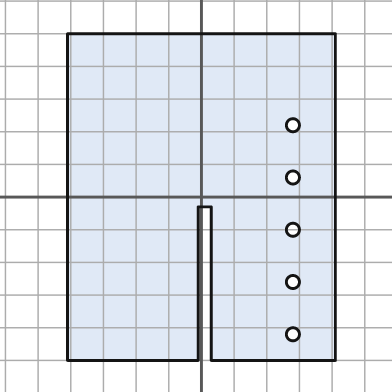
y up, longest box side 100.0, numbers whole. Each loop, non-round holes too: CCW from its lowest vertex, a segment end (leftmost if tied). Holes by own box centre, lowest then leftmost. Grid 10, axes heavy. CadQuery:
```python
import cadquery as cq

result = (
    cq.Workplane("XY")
    .moveTo(-41.0, -50.0)
    .lineTo(-1.0, -50.0)
    .lineTo(-1.0, -3.0)
    .lineTo(3.0, -3.0)
    .lineTo(3.0, -50.0)
    .lineTo(41.0, -50.0)
    .lineTo(41.0, 50.0)
    .lineTo(-41.0, 50.0)
    .close()
    .moveTo(28.0, -42.0)
    .circle(2.0)
    .moveTo(28.0, -26.0)
    .circle(2.0)
    .moveTo(28.0, -10.0)
    .circle(2.0)
    .moveTo(28.0, 6.0)
    .circle(2.0)
    .moveTo(28.0, 22.0)
    .circle(2.0)
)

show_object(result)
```